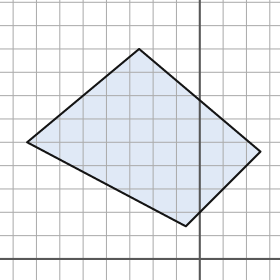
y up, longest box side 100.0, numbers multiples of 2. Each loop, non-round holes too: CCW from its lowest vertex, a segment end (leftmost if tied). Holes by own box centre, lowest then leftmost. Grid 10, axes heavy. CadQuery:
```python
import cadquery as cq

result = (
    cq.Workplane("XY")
    .moveTo(-6.0, 14.0)
    .lineTo(26.0, 46.0)
    .lineTo(-26.0, 90.0)
    .lineTo(-74.0, 50.0)
    .close()
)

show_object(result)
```